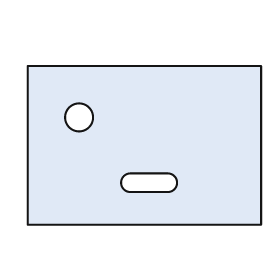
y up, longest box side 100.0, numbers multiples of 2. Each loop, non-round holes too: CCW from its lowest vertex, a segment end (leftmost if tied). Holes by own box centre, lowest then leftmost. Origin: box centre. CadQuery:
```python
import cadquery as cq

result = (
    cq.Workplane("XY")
    .moveTo(-50.0, -34.0)
    .lineTo(50.0, -34.0)
    .lineTo(50.0, 34.0)
    .lineTo(-50.0, 34.0)
    .close()
    .moveTo(-6.0, -20.0)
    .lineTo(10.0, -20.0)
    .threePointArc((14.0, -16.0), (10.0, -12.0))
    .lineTo(-6.0, -12.0)
    .threePointArc((-10.0, -16.0), (-6.0, -20.0))
    .close()
    .moveTo(-28.0, 12.0)
    .circle(6.0)
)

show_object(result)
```